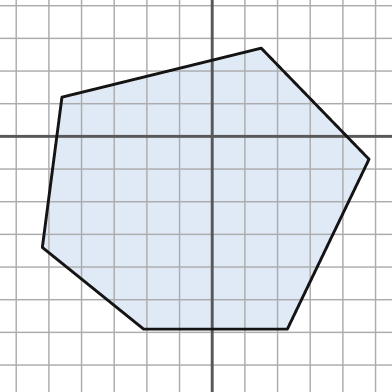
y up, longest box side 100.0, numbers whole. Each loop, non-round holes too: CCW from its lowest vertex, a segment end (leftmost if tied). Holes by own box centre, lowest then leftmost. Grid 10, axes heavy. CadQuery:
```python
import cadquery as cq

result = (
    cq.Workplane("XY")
    .moveTo(-21.0, -59.0)
    .lineTo(23.0, -59.0)
    .lineTo(48.0, -7.0)
    .lineTo(15.0, 27.0)
    .lineTo(-46.0, 12.0)
    .lineTo(-52.0, -34.0)
    .close()
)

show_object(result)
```